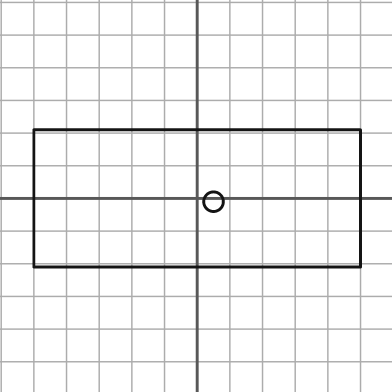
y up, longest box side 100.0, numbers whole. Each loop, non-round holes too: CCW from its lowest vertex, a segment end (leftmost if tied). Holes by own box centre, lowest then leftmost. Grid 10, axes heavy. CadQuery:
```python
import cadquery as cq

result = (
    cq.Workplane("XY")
    .moveTo(-50.0, -21.0)
    .lineTo(50.0, -21.0)
    .lineTo(50.0, 21.0)
    .lineTo(-50.0, 21.0)
    .close()
    .moveTo(5.0, -1.0)
    .circle(3.0)
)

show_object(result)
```